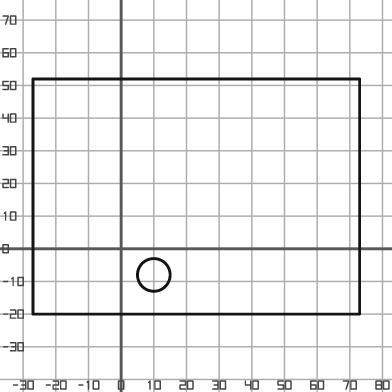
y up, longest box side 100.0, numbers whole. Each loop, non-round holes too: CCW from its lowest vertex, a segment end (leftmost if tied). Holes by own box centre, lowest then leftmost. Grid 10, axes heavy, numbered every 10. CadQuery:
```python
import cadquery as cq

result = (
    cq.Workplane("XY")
    .moveTo(-27.0, -20.0)
    .lineTo(73.0, -20.0)
    .lineTo(73.0, 52.0)
    .lineTo(-27.0, 52.0)
    .close()
    .moveTo(10.0, -8.0)
    .circle(5.0)
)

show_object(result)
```